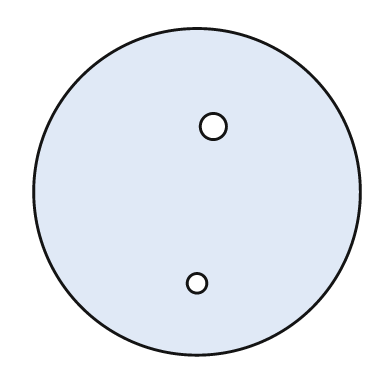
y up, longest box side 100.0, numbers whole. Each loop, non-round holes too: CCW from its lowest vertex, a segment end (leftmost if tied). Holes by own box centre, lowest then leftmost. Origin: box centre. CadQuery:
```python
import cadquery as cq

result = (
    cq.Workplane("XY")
    .moveTo(0.0, 0.0)
    .circle(50.0)
    .moveTo(0.0, -28.0)
    .circle(3.0)
    .moveTo(5.0, 20.0)
    .circle(4.0)
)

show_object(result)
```